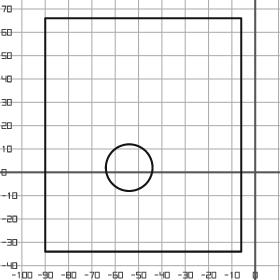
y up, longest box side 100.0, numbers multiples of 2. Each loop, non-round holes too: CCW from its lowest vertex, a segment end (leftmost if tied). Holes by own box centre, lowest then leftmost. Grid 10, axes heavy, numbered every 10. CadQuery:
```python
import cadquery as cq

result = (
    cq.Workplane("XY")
    .moveTo(-90.0, -34.0)
    .lineTo(-6.0, -34.0)
    .lineTo(-6.0, 66.0)
    .lineTo(-90.0, 66.0)
    .close()
    .moveTo(-54.0, 2.0)
    .circle(10.0)
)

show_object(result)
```